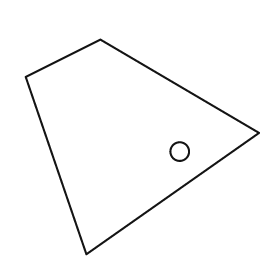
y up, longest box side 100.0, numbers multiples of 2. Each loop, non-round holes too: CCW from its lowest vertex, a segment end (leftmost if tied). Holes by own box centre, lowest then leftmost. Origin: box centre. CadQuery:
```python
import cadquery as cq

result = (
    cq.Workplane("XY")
    .moveTo(-24.0, -46.0)
    .lineTo(50.0, 6.0)
    .lineTo(-18.0, 46.0)
    .lineTo(-50.0, 30.0)
    .close()
    .moveTo(16.0, -2.0)
    .circle(4.0)
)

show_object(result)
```